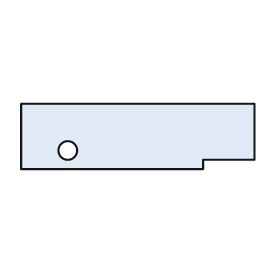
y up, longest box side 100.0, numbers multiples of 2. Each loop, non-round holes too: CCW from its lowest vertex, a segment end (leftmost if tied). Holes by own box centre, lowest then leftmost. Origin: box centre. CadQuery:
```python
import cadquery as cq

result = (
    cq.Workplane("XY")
    .moveTo(-50.0, -14.0)
    .lineTo(28.0, -14.0)
    .lineTo(28.0, -10.0)
    .lineTo(50.0, -10.0)
    .lineTo(50.0, 14.0)
    .lineTo(-50.0, 14.0)
    .close()
    .moveTo(-30.0, -6.0)
    .circle(4.0)
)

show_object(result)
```